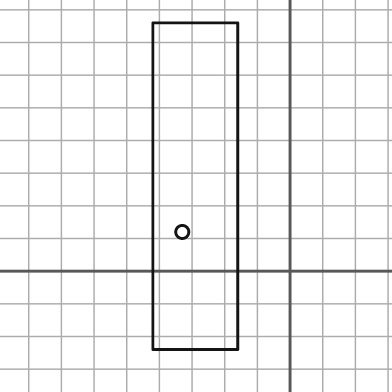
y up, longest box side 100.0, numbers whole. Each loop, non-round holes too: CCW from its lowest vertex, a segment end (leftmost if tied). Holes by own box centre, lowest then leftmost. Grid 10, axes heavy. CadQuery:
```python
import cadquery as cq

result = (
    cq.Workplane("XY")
    .moveTo(-42.0, -24.0)
    .lineTo(-16.0, -24.0)
    .lineTo(-16.0, 76.0)
    .lineTo(-42.0, 76.0)
    .close()
    .moveTo(-33.0, 12.0)
    .circle(2.0)
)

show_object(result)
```